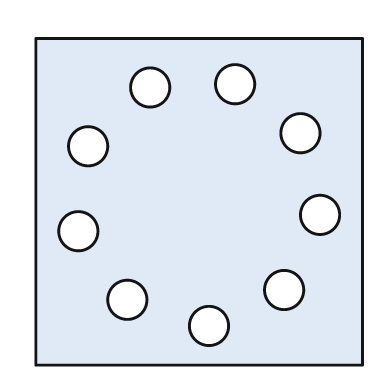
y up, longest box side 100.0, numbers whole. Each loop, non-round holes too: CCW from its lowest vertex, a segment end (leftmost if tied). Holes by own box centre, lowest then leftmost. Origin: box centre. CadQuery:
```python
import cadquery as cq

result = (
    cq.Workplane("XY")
    .moveTo(-50.0, -50.0)
    .lineTo(50.0, -50.0)
    .lineTo(50.0, 50.0)
    .lineTo(-50.0, 50.0)
    .close()
    .moveTo(3.0, -38.0)
    .circle(6.0)
    .moveTo(-22.0, -30.0)
    .circle(6.0)
    .moveTo(26.0, -27.0)
    .circle(6.0)
    .moveTo(-37.0, -9.0)
    .circle(6.0)
    .moveTo(37.0, -4.0)
    .circle(6.0)
    .moveTo(-34.0, 17.0)
    .circle(6.0)
    .moveTo(31.0, 21.0)
    .circle(6.0)
    .moveTo(-15.0, 35.0)
    .circle(6.0)
    .moveTo(11.0, 36.0)
    .circle(6.0)
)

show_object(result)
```